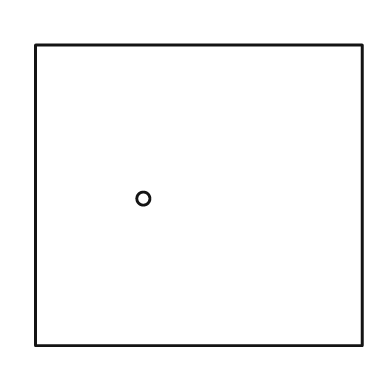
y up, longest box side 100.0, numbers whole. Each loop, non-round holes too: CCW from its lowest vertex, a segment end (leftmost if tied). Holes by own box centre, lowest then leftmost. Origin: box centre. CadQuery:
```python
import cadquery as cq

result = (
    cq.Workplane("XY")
    .moveTo(-50.0, -46.0)
    .lineTo(50.0, -46.0)
    .lineTo(50.0, 46.0)
    .lineTo(-50.0, 46.0)
    .close()
    .moveTo(-17.0, -1.0)
    .circle(2.0)
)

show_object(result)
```